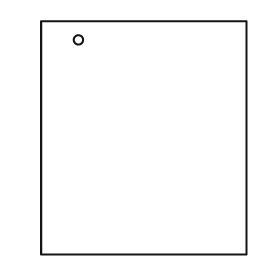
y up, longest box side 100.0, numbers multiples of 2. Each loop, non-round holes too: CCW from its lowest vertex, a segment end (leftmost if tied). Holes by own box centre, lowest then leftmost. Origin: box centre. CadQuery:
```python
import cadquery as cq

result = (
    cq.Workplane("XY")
    .moveTo(-44.0, -50.0)
    .lineTo(44.0, -50.0)
    .lineTo(44.0, 50.0)
    .lineTo(-44.0, 50.0)
    .close()
    .moveTo(-28.0, 42.0)
    .circle(2.0)
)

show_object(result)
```